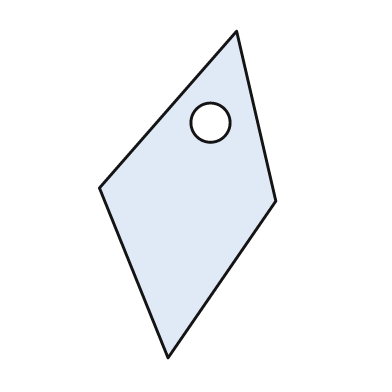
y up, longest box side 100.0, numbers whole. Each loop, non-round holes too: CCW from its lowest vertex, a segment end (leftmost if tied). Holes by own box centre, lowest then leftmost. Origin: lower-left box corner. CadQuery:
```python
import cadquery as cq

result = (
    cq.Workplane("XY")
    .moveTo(21.0, 0.0)
    .lineTo(54.0, 48.0)
    .lineTo(42.0, 100.0)
    .lineTo(0.0, 52.0)
    .close()
    .moveTo(34.0, 72.0)
    .circle(6.0)
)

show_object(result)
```